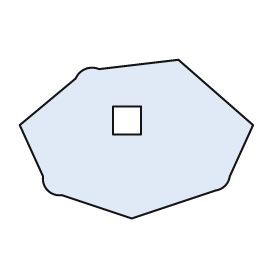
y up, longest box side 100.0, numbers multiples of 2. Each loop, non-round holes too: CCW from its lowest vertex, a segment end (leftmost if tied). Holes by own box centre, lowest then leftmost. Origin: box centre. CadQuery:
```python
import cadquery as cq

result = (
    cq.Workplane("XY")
    .moveTo(-2.0, -34.0)
    .lineTo(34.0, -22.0)
    .threePointArc((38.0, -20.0), (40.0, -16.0))
    .lineTo(50.0, 6.0)
    .lineTo(18.0, 34.0)
    .lineTo(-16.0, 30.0)
    .threePointArc((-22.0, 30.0), (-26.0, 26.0))
    .lineTo(-50.0, 6.0)
    .lineTo(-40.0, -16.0)
    .threePointArc((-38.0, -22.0), (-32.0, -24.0))
    .close()
    .moveTo(-10.0, 2.0)
    .lineTo(2.0, 2.0)
    .lineTo(2.0, 14.0)
    .lineTo(-10.0, 14.0)
    .close()
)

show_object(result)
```